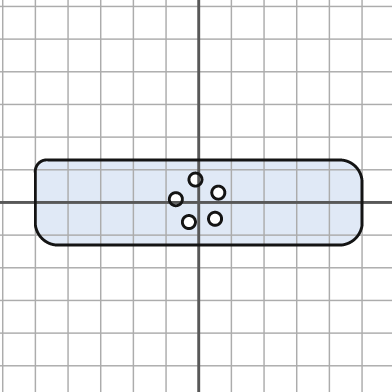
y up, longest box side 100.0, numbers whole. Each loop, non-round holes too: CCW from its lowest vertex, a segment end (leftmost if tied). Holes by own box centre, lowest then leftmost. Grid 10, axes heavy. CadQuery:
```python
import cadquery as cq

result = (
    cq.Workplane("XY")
    .moveTo(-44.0, -13.0)
    .lineTo(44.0, -13.0)
    .threePointArc((48.0, -11.0), (50.0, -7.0))
    .lineTo(50.0, 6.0)
    .threePointArc((48.0, 11.0), (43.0, 13.0))
    .lineTo(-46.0, 13.0)
    .threePointArc((-49.0, 12.0), (-50.0, 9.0))
    .lineTo(-50.0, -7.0)
    .threePointArc((-48.0, -11.0), (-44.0, -13.0))
    .close()
    .moveTo(-3.0, -6.0)
    .circle(2.0)
    .moveTo(5.0, -5.0)
    .circle(2.0)
    .moveTo(-7.0, 1.0)
    .circle(2.0)
    .moveTo(6.0, 3.0)
    .circle(2.0)
    .moveTo(-1.0, 7.0)
    .circle(2.0)
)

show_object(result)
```